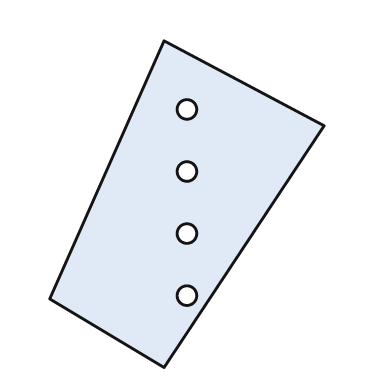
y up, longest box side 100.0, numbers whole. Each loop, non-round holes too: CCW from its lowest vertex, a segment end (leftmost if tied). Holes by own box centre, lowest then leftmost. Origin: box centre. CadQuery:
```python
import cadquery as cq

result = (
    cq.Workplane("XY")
    .moveTo(-7.0, -50.0)
    .lineTo(42.0, 24.0)
    .lineTo(-7.0, 50.0)
    .lineTo(-42.0, -29.0)
    .close()
    .moveTo(0.0, -28.0)
    .circle(3.0)
    .moveTo(0.0, -9.0)
    .circle(3.0)
    .moveTo(0.0, 10.0)
    .circle(3.0)
    .moveTo(0.0, 29.0)
    .circle(3.0)
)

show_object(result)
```